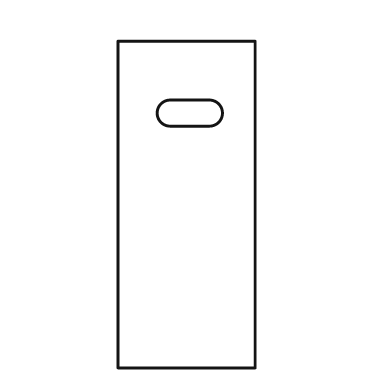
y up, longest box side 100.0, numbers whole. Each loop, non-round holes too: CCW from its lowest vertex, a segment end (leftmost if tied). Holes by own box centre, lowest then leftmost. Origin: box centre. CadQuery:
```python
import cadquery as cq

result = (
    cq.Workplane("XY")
    .moveTo(-21.0, -50.0)
    .lineTo(21.0, -50.0)
    .lineTo(21.0, 50.0)
    .lineTo(-21.0, 50.0)
    .close()
    .moveTo(-5.0, 24.0)
    .lineTo(7.0, 24.0)
    .threePointArc((11.0, 28.0), (7.0, 32.0))
    .lineTo(-5.0, 32.0)
    .threePointArc((-9.0, 28.0), (-5.0, 24.0))
    .close()
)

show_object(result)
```